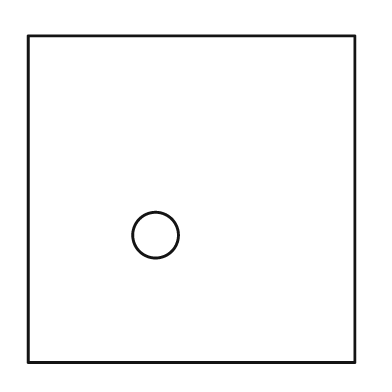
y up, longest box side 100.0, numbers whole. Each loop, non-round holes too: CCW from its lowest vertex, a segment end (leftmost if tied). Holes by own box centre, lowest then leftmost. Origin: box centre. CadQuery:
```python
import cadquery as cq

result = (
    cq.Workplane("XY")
    .moveTo(-50.0, -50.0)
    .lineTo(50.0, -50.0)
    .lineTo(50.0, 50.0)
    .lineTo(-50.0, 50.0)
    .close()
    .moveTo(-11.0, -11.0)
    .circle(7.0)
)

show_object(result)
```